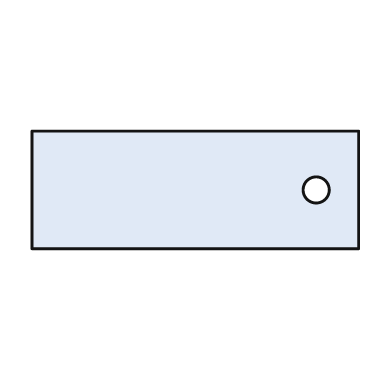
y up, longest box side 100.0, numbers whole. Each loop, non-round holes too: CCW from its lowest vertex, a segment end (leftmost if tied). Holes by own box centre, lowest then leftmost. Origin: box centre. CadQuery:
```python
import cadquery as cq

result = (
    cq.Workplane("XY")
    .moveTo(-50.0, -18.0)
    .lineTo(50.0, -18.0)
    .lineTo(50.0, 18.0)
    .lineTo(-50.0, 18.0)
    .close()
    .moveTo(37.0, 0.0)
    .circle(4.0)
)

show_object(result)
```